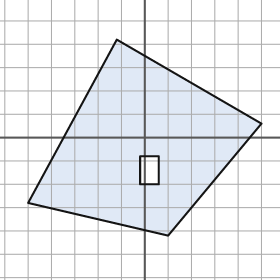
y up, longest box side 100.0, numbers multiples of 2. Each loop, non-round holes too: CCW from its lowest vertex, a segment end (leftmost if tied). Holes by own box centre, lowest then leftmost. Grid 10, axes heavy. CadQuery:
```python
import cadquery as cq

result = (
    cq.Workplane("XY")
    .moveTo(10.0, -42.0)
    .lineTo(50.0, 6.0)
    .lineTo(-12.0, 42.0)
    .lineTo(-50.0, -28.0)
    .close()
    .moveTo(-2.0, -20.0)
    .lineTo(6.0, -20.0)
    .lineTo(6.0, -8.0)
    .lineTo(-2.0, -8.0)
    .close()
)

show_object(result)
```